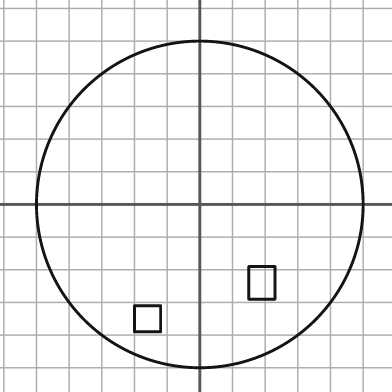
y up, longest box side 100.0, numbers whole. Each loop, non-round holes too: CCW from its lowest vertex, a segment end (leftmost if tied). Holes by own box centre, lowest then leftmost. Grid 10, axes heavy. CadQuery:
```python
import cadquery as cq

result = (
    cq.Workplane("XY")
    .moveTo(0.0, 0.0)
    .circle(50.0)
    .moveTo(-20.0, -39.0)
    .lineTo(-12.0, -39.0)
    .lineTo(-12.0, -31.0)
    .lineTo(-20.0, -31.0)
    .close()
    .moveTo(15.0, -29.0)
    .lineTo(23.0, -29.0)
    .lineTo(23.0, -19.0)
    .lineTo(15.0, -19.0)
    .close()
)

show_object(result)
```